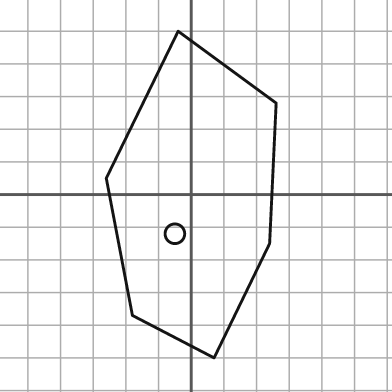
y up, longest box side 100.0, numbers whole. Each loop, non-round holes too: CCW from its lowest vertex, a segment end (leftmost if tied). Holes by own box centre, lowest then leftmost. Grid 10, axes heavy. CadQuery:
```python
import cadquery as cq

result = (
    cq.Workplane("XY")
    .moveTo(7.0, -50.0)
    .lineTo(24.0, -15.0)
    .lineTo(26.0, 28.0)
    .lineTo(-4.0, 50.0)
    .lineTo(-26.0, 5.0)
    .lineTo(-18.0, -37.0)
    .close()
    .moveTo(-5.0, -12.0)
    .circle(3.0)
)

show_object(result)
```